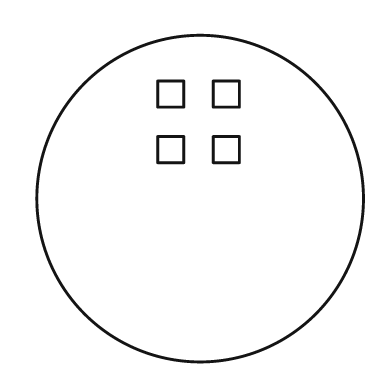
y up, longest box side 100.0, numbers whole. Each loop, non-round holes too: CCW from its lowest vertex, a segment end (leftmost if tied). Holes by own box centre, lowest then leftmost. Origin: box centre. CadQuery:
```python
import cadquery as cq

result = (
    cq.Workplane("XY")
    .moveTo(0.0, 0.0)
    .circle(50.0)
    .moveTo(-13.0, 11.0)
    .lineTo(-5.0, 11.0)
    .lineTo(-5.0, 19.0)
    .lineTo(-13.0, 19.0)
    .close()
    .moveTo(4.0, 11.0)
    .lineTo(12.0, 11.0)
    .lineTo(12.0, 19.0)
    .lineTo(4.0, 19.0)
    .close()
    .moveTo(-13.0, 28.0)
    .lineTo(-5.0, 28.0)
    .lineTo(-5.0, 36.0)
    .lineTo(-13.0, 36.0)
    .close()
    .moveTo(4.0, 28.0)
    .lineTo(12.0, 28.0)
    .lineTo(12.0, 36.0)
    .lineTo(4.0, 36.0)
    .close()
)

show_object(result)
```